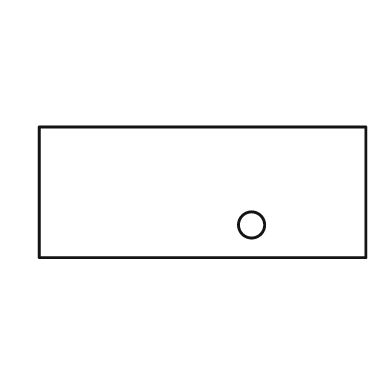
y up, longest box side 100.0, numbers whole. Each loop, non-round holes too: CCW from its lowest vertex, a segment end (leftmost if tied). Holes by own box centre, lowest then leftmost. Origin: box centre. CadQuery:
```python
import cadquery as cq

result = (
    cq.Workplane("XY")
    .moveTo(-50.0, -20.0)
    .lineTo(50.0, -20.0)
    .lineTo(50.0, 20.0)
    .lineTo(-50.0, 20.0)
    .close()
    .moveTo(15.0, -10.0)
    .circle(4.0)
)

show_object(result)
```